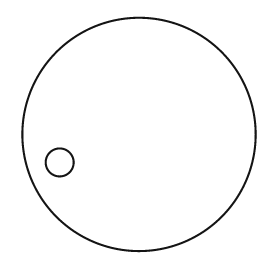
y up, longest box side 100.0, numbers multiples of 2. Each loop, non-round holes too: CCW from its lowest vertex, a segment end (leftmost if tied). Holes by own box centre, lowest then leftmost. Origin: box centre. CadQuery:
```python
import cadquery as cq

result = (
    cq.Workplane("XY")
    .moveTo(0.0, 0.0)
    .circle(50.0)
    .moveTo(-34.0, -12.0)
    .circle(6.0)
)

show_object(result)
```